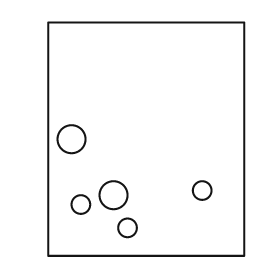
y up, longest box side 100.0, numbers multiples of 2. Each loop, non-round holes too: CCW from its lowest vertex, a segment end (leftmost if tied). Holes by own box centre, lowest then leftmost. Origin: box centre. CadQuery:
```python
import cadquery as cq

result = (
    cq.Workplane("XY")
    .moveTo(-42.0, -50.0)
    .lineTo(42.0, -50.0)
    .lineTo(42.0, 50.0)
    .lineTo(-42.0, 50.0)
    .close()
    .moveTo(-8.0, -38.0)
    .circle(4.0)
    .moveTo(-28.0, -28.0)
    .circle(4.0)
    .moveTo(-14.0, -24.0)
    .circle(6.0)
    .moveTo(24.0, -22.0)
    .circle(4.0)
    .moveTo(-32.0, 0.0)
    .circle(6.0)
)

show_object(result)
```